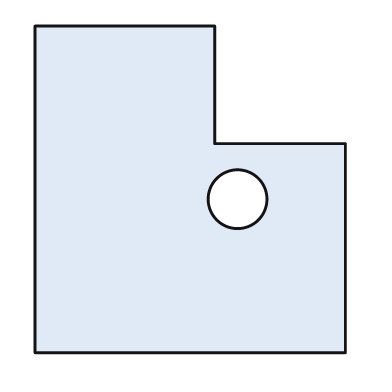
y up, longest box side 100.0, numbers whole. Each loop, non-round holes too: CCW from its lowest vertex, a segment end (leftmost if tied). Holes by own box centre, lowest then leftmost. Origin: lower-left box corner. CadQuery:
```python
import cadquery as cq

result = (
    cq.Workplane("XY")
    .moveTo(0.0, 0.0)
    .lineTo(95.0, 0.0)
    .lineTo(95.0, 64.0)
    .lineTo(55.0, 64.0)
    .lineTo(55.0, 100.0)
    .lineTo(0.0, 100.0)
    .close()
    .moveTo(62.0, 47.0)
    .circle(9.0)
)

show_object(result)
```